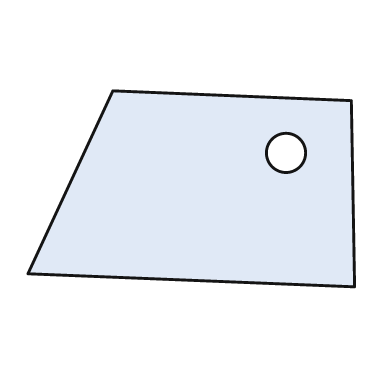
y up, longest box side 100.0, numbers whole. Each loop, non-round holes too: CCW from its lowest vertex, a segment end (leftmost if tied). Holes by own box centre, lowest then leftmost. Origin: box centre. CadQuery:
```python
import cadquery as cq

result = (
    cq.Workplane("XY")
    .moveTo(50.0, -30.0)
    .lineTo(49.0, 27.0)
    .lineTo(-24.0, 30.0)
    .lineTo(-50.0, -26.0)
    .close()
    .moveTo(29.0, 11.0)
    .circle(6.0)
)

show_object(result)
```